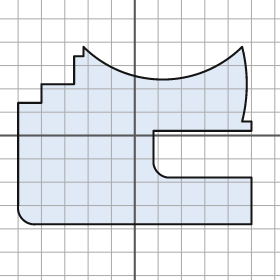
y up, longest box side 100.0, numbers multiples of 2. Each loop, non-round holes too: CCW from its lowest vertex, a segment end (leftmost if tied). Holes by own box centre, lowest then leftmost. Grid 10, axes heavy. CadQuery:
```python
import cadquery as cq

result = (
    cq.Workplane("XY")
    .moveTo(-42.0, -38.0)
    .lineTo(50.0, -38.0)
    .lineTo(50.0, -18.0)
    .lineTo(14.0, -18.0)
    .threePointArc((10.0, -16.0), (8.0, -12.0))
    .lineTo(8.0, 2.0)
    .lineTo(50.0, 2.0)
    .lineTo(50.0, 6.0)
    .lineTo(46.0, 6.0)
    .threePointArc((48.0, 22.0), (46.0, 38.0))
    .threePointArc((12.0, 24.0), (-22.0, 38.0))
    .lineTo(-22.0, 34.0)
    .lineTo(-26.0, 34.0)
    .lineTo(-26.0, 22.0)
    .lineTo(-40.0, 22.0)
    .lineTo(-40.0, 14.0)
    .lineTo(-50.0, 14.0)
    .lineTo(-50.0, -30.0)
    .threePointArc((-48.0, -36.0), (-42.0, -38.0))
    .close()
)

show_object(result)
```